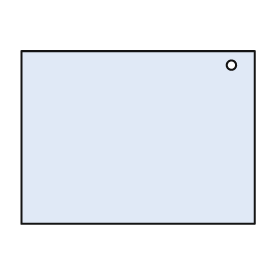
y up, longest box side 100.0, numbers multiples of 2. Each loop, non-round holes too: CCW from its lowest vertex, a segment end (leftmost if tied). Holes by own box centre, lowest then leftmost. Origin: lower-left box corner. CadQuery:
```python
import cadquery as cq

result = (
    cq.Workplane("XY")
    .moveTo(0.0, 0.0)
    .lineTo(100.0, 0.0)
    .lineTo(100.0, 74.0)
    .lineTo(0.0, 74.0)
    .close()
    .moveTo(90.0, 68.0)
    .circle(2.0)
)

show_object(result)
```